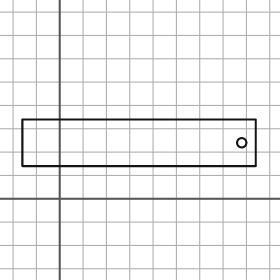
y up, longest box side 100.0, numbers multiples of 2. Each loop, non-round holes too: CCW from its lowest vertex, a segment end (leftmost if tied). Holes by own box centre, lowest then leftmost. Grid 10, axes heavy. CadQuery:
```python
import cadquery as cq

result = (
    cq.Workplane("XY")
    .moveTo(-16.0, 14.0)
    .lineTo(84.0, 14.0)
    .lineTo(84.0, 34.0)
    .lineTo(-16.0, 34.0)
    .close()
    .moveTo(78.0, 24.0)
    .circle(2.0)
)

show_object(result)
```